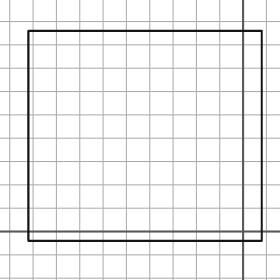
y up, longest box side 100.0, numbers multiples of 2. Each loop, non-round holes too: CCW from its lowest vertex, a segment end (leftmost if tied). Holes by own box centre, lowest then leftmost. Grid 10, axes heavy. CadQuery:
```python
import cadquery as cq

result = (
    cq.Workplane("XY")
    .moveTo(-92.0, -4.0)
    .lineTo(8.0, -4.0)
    .lineTo(8.0, 86.0)
    .lineTo(-92.0, 86.0)
    .close()
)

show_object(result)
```